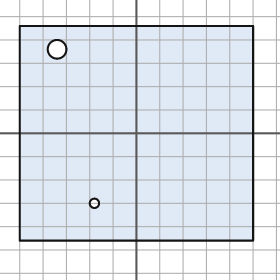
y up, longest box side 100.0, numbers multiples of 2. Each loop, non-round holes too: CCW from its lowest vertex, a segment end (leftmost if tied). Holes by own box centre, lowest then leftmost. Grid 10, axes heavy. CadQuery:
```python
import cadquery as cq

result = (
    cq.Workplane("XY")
    .moveTo(-50.0, -46.0)
    .lineTo(50.0, -46.0)
    .lineTo(50.0, 46.0)
    .lineTo(-50.0, 46.0)
    .close()
    .moveTo(-18.0, -30.0)
    .circle(2.0)
    .moveTo(-34.0, 36.0)
    .circle(4.0)
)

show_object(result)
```